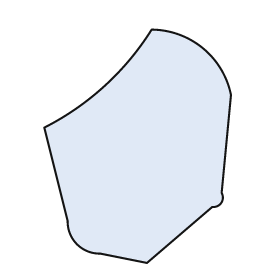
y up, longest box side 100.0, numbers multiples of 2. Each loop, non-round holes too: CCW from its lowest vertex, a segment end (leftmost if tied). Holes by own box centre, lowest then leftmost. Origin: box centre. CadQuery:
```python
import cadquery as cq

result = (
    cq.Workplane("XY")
    .moveTo(4.0, -50.0)
    .lineTo(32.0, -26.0)
    .threePointArc((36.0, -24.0), (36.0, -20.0))
    .lineTo(40.0, 22.0)
    .threePointArc((28.0, 42.0), (6.0, 50.0))
    .threePointArc((-14.0, 26.0), (-40.0, 8.0))
    .lineTo(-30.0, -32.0)
    .threePointArc((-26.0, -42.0), (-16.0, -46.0))
    .close()
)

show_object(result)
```